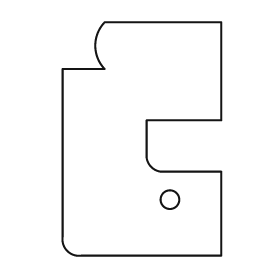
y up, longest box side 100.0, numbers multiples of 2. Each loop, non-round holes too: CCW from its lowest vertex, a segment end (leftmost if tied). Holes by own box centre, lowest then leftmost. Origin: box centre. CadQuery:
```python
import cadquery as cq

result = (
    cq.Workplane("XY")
    .moveTo(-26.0, -50.0)
    .lineTo(34.0, -50.0)
    .lineTo(34.0, -14.0)
    .lineTo(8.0, -14.0)
    .threePointArc((4.0, -12.0), (2.0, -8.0))
    .lineTo(2.0, 8.0)
    .lineTo(34.0, 8.0)
    .lineTo(34.0, 50.0)
    .lineTo(-16.0, 50.0)
    .threePointArc((-20.0, 40.0), (-16.0, 30.0))
    .lineTo(-34.0, 30.0)
    .lineTo(-34.0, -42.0)
    .threePointArc((-32.0, -48.0), (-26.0, -50.0))
    .close()
    .moveTo(12.0, -26.0)
    .circle(4.0)
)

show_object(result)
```